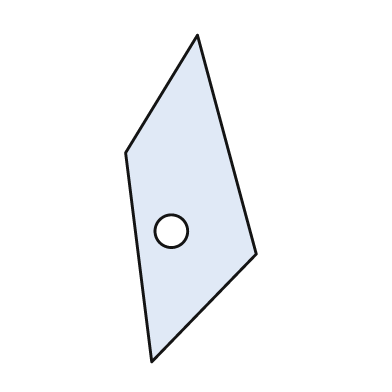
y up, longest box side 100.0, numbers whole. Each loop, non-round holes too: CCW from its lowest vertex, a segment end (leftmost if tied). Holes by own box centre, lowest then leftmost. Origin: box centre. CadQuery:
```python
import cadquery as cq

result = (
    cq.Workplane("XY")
    .moveTo(-12.0, -50.0)
    .lineTo(20.0, -17.0)
    .lineTo(2.0, 50.0)
    .lineTo(-20.0, 14.0)
    .close()
    .moveTo(-6.0, -10.0)
    .circle(5.0)
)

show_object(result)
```